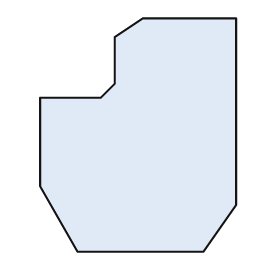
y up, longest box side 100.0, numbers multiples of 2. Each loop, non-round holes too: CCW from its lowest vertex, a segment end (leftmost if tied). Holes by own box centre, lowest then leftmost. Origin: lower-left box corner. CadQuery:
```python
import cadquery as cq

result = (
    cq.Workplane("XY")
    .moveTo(16.0, 0.0)
    .lineTo(70.0, 0.0)
    .lineTo(84.0, 20.0)
    .lineTo(84.0, 100.0)
    .lineTo(44.0, 100.0)
    .lineTo(32.0, 92.0)
    .lineTo(32.0, 72.0)
    .lineTo(26.0, 66.0)
    .lineTo(0.0, 66.0)
    .lineTo(0.0, 28.0)
    .close()
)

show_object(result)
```